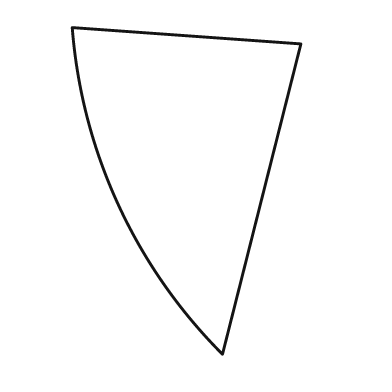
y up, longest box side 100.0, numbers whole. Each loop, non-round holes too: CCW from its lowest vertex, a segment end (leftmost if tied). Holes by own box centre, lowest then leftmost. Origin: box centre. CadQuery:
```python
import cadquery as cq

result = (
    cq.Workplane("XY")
    .moveTo(11.0, -50.0)
    .lineTo(35.0, 45.0)
    .lineTo(-35.0, 50.0)
    .threePointArc((-21.0, -4.0), (11.0, -50.0))
    .close()
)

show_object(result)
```